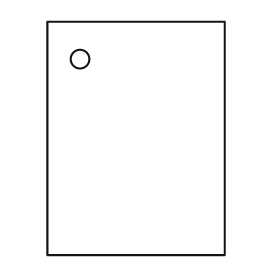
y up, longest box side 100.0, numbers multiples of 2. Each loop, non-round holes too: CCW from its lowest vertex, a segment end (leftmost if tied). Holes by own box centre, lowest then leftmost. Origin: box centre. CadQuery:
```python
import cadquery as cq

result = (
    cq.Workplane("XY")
    .moveTo(-38.0, -50.0)
    .lineTo(38.0, -50.0)
    .lineTo(38.0, 50.0)
    .lineTo(-38.0, 50.0)
    .close()
    .moveTo(-24.0, 34.0)
    .circle(4.0)
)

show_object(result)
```